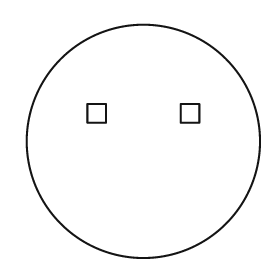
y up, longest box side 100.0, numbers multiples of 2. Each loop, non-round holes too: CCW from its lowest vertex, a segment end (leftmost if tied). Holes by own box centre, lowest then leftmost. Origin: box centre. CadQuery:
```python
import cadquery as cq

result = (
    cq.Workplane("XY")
    .moveTo(0.0, 0.0)
    .circle(50.0)
    .moveTo(-24.0, 8.0)
    .lineTo(-16.0, 8.0)
    .lineTo(-16.0, 16.0)
    .lineTo(-24.0, 16.0)
    .close()
    .moveTo(16.0, 8.0)
    .lineTo(24.0, 8.0)
    .lineTo(24.0, 16.0)
    .lineTo(16.0, 16.0)
    .close()
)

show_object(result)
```